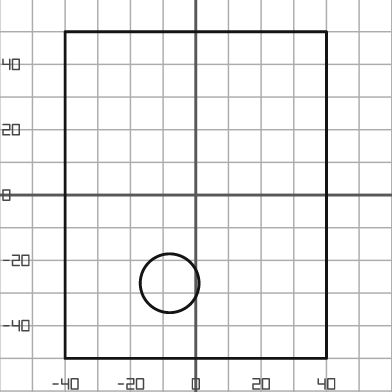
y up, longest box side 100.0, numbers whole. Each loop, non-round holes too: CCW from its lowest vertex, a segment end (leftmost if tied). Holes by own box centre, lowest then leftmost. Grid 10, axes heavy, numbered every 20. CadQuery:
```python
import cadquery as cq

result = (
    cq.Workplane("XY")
    .moveTo(-40.0, -50.0)
    .lineTo(40.0, -50.0)
    .lineTo(40.0, 50.0)
    .lineTo(-40.0, 50.0)
    .close()
    .moveTo(-8.0, -27.0)
    .circle(9.0)
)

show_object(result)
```